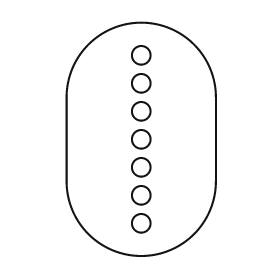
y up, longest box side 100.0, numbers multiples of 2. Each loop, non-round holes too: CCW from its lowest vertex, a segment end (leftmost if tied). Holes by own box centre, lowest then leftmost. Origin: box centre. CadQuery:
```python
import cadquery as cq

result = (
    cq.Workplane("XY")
    .moveTo(-32.0, -18.0)
    .threePointArc((0.0, -50.0), (32.0, -18.0))
    .lineTo(32.0, 18.0)
    .threePointArc((0.0, 50.0), (-32.0, 18.0))
    .close()
    .moveTo(0.0, -36.0)
    .circle(4.0)
    .moveTo(0.0, -24.0)
    .circle(4.0)
    .moveTo(0.0, -12.0)
    .circle(4.0)
    .moveTo(0.0, 0.0)
    .circle(4.0)
    .moveTo(0.0, 12.0)
    .circle(4.0)
    .moveTo(0.0, 24.0)
    .circle(4.0)
    .moveTo(0.0, 36.0)
    .circle(4.0)
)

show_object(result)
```